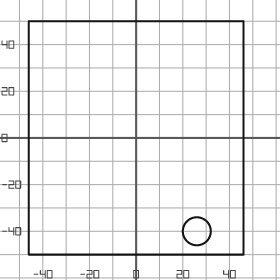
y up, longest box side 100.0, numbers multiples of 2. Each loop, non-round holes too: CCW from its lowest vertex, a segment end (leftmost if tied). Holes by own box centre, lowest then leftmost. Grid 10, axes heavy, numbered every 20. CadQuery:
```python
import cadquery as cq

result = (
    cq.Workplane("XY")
    .moveTo(-46.0, -50.0)
    .lineTo(46.0, -50.0)
    .lineTo(46.0, 50.0)
    .lineTo(-46.0, 50.0)
    .close()
    .moveTo(26.0, -40.0)
    .circle(6.0)
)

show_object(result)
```